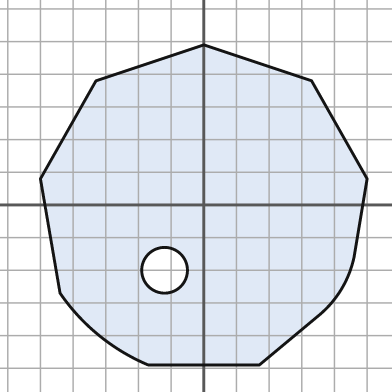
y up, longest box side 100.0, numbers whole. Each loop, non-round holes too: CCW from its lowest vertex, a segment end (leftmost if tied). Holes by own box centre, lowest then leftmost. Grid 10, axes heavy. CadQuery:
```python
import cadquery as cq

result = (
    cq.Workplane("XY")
    .moveTo(-17.0, -49.0)
    .lineTo(17.0, -49.0)
    .lineTo(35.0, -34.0)
    .threePointArc((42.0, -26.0), (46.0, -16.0))
    .lineTo(50.0, 8.0)
    .lineTo(33.0, 38.0)
    .lineTo(0.0, 49.0)
    .lineTo(-33.0, 38.0)
    .lineTo(-50.0, 8.0)
    .lineTo(-44.0, -27.0)
    .threePointArc((-32.0, -40.0), (-17.0, -49.0))
    .close()
    .moveTo(-12.0, -20.0)
    .circle(7.0)
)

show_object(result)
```